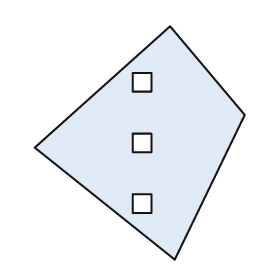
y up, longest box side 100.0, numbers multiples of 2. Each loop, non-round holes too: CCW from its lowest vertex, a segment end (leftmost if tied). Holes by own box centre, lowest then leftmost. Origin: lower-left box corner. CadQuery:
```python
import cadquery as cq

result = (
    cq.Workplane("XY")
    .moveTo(60.0, 0.0)
    .lineTo(90.0, 62.0)
    .lineTo(58.0, 100.0)
    .lineTo(0.0, 48.0)
    .close()
    .moveTo(42.0, 20.0)
    .lineTo(50.0, 20.0)
    .lineTo(50.0, 28.0)
    .lineTo(42.0, 28.0)
    .close()
    .moveTo(42.0, 46.0)
    .lineTo(50.0, 46.0)
    .lineTo(50.0, 54.0)
    .lineTo(42.0, 54.0)
    .close()
    .moveTo(42.0, 72.0)
    .lineTo(50.0, 72.0)
    .lineTo(50.0, 80.0)
    .lineTo(42.0, 80.0)
    .close()
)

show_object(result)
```